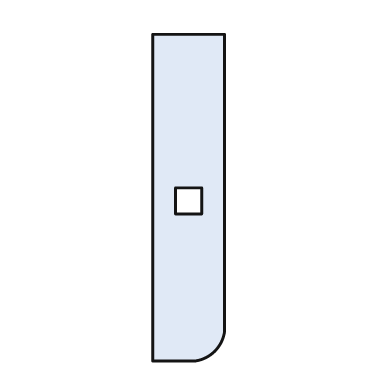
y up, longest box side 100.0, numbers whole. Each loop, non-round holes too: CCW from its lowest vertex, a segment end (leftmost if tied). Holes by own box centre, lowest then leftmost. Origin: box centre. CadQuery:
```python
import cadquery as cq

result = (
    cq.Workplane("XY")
    .moveTo(-11.0, -50.0)
    .lineTo(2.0, -50.0)
    .threePointArc((8.0, -47.0), (11.0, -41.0))
    .lineTo(11.0, 50.0)
    .lineTo(-11.0, 50.0)
    .close()
    .moveTo(-4.0, -5.0)
    .lineTo(4.0, -5.0)
    .lineTo(4.0, 3.0)
    .lineTo(-4.0, 3.0)
    .close()
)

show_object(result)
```